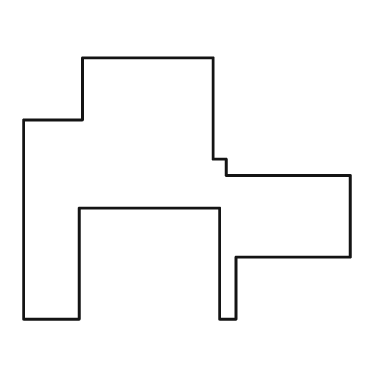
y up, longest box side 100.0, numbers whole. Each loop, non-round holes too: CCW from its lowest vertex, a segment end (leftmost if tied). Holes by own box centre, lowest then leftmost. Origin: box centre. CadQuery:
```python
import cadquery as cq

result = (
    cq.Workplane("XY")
    .moveTo(-50.0, -40.0)
    .lineTo(-33.0, -40.0)
    .lineTo(-33.0, -6.0)
    .lineTo(10.0, -6.0)
    .lineTo(10.0, -40.0)
    .lineTo(15.0, -40.0)
    .lineTo(15.0, -21.0)
    .lineTo(50.0, -21.0)
    .lineTo(50.0, 4.0)
    .lineTo(12.0, 4.0)
    .lineTo(12.0, 9.0)
    .lineTo(8.0, 9.0)
    .lineTo(8.0, 40.0)
    .lineTo(-32.0, 40.0)
    .lineTo(-32.0, 21.0)
    .lineTo(-50.0, 21.0)
    .close()
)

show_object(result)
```